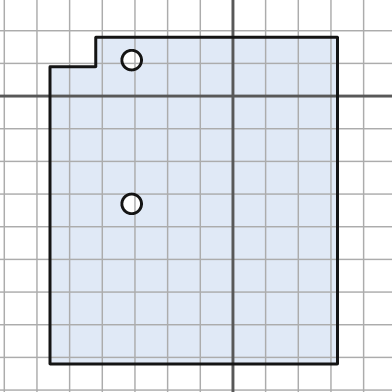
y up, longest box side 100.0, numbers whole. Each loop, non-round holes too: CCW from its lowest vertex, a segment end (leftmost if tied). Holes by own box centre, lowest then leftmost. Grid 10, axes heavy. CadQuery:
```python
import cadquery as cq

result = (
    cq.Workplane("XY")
    .moveTo(-56.0, -82.0)
    .lineTo(32.0, -82.0)
    .lineTo(32.0, 18.0)
    .lineTo(-42.0, 18.0)
    .lineTo(-42.0, 9.0)
    .lineTo(-56.0, 9.0)
    .close()
    .moveTo(-31.0, -33.0)
    .circle(3.0)
    .moveTo(-31.0, 11.0)
    .circle(3.0)
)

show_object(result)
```